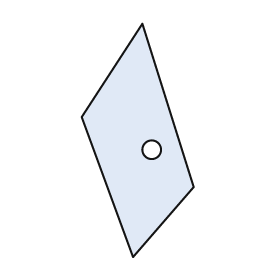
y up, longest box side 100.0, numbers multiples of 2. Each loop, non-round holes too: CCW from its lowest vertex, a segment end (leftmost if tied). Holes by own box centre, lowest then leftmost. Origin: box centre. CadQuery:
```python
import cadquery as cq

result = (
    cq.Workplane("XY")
    .moveTo(-2.0, -50.0)
    .lineTo(24.0, -20.0)
    .lineTo(2.0, 50.0)
    .lineTo(-24.0, 10.0)
    .close()
    .moveTo(6.0, -4.0)
    .circle(4.0)
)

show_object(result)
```